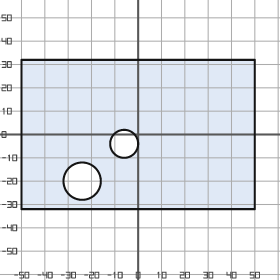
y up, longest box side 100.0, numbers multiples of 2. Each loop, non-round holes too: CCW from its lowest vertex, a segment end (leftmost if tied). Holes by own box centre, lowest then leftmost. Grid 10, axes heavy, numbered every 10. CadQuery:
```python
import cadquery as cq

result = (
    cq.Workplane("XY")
    .moveTo(-50.0, -32.0)
    .lineTo(50.0, -32.0)
    .lineTo(50.0, 32.0)
    .lineTo(-50.0, 32.0)
    .close()
    .moveTo(-24.0, -20.0)
    .circle(8.0)
    .moveTo(-6.0, -4.0)
    .circle(6.0)
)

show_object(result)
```